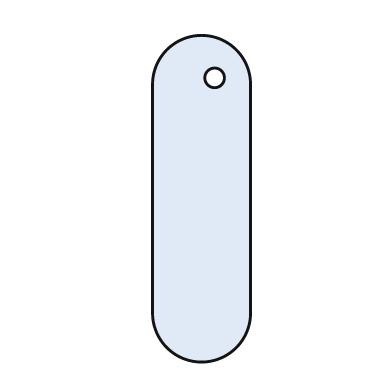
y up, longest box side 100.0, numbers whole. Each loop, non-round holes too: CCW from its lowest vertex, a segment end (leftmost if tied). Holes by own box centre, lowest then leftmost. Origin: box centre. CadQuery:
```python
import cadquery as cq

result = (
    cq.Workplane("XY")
    .moveTo(-15.0, -35.0)
    .threePointArc((0.0, -50.0), (15.0, -35.0))
    .lineTo(15.0, 35.0)
    .threePointArc((0.0, 50.0), (-15.0, 35.0))
    .close()
    .moveTo(4.0, 37.0)
    .circle(3.0)
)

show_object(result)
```